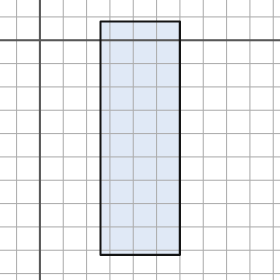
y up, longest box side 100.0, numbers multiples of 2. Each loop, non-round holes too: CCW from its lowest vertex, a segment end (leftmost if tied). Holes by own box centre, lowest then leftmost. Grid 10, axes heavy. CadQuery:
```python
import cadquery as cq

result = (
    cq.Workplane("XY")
    .moveTo(26.0, -92.0)
    .lineTo(60.0, -92.0)
    .lineTo(60.0, 8.0)
    .lineTo(26.0, 8.0)
    .close()
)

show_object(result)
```